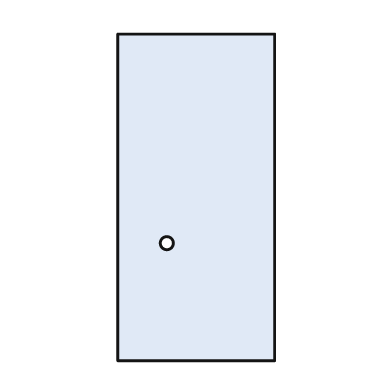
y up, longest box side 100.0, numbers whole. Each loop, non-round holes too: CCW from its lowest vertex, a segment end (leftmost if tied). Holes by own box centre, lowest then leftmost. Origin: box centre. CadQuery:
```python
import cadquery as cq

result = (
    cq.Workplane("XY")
    .moveTo(-24.0, -50.0)
    .lineTo(24.0, -50.0)
    .lineTo(24.0, 50.0)
    .lineTo(-24.0, 50.0)
    .close()
    .moveTo(-9.0, -14.0)
    .circle(2.0)
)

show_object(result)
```